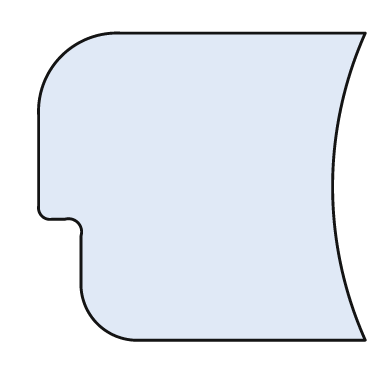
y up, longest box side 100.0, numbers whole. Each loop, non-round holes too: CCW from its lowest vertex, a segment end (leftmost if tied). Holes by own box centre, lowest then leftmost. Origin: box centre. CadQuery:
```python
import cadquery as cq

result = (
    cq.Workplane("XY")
    .moveTo(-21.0, -47.0)
    .lineTo(50.0, -47.0)
    .threePointArc((40.0, 0.0), (50.0, 47.0))
    .lineTo(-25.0, 47.0)
    .threePointArc((-43.0, 40.0), (-50.0, 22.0))
    .lineTo(-50.0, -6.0)
    .threePointArc((-49.0, -9.0), (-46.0, -10.0))
    .lineTo(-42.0, -10.0)
    .threePointArc((-38.0, -11.0), (-37.0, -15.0))
    .lineTo(-37.0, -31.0)
    .threePointArc((-32.0, -42.0), (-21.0, -47.0))
    .close()
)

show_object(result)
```